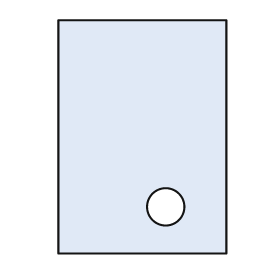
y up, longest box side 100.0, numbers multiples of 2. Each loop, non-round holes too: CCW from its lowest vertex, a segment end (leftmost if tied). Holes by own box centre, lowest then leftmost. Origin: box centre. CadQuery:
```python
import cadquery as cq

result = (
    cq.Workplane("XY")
    .moveTo(-36.0, -50.0)
    .lineTo(36.0, -50.0)
    .lineTo(36.0, 50.0)
    .lineTo(-36.0, 50.0)
    .close()
    .moveTo(10.0, -30.0)
    .circle(8.0)
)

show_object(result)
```